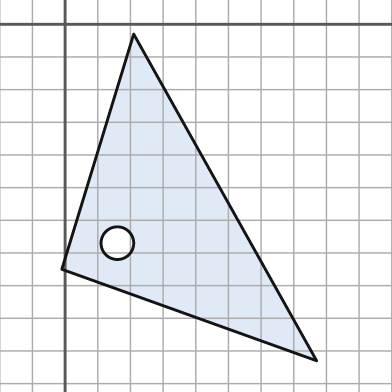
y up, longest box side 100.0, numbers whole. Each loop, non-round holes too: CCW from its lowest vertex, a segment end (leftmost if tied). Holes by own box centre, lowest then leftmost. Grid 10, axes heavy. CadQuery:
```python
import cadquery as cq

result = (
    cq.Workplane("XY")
    .moveTo(77.0, -103.0)
    .lineTo(21.0, -3.0)
    .lineTo(-1.0, -75.0)
    .close()
    .moveTo(16.0, -67.0)
    .circle(5.0)
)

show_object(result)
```